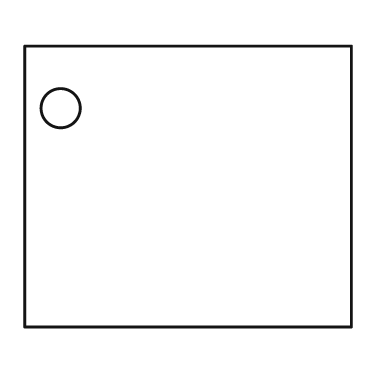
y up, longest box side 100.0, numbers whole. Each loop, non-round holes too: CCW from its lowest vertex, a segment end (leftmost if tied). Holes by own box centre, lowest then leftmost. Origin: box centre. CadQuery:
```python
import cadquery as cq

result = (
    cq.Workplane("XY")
    .moveTo(-50.0, -43.0)
    .lineTo(50.0, -43.0)
    .lineTo(50.0, 43.0)
    .lineTo(-50.0, 43.0)
    .close()
    .moveTo(-39.0, 24.0)
    .circle(6.0)
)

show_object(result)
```